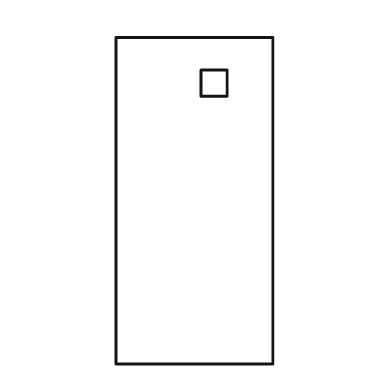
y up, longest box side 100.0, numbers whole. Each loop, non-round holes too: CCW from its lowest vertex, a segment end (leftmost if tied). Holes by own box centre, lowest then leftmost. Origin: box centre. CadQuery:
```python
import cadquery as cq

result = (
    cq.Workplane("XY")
    .moveTo(-24.0, -50.0)
    .lineTo(24.0, -50.0)
    .lineTo(24.0, 50.0)
    .lineTo(-24.0, 50.0)
    .close()
    .moveTo(2.0, 32.0)
    .lineTo(10.0, 32.0)
    .lineTo(10.0, 40.0)
    .lineTo(2.0, 40.0)
    .close()
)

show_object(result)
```